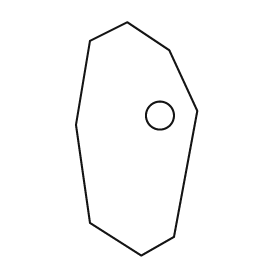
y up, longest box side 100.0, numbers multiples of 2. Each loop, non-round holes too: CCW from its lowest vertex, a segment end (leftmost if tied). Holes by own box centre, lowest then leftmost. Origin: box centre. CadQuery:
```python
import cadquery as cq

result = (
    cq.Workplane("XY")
    .moveTo(2.0, -50.0)
    .lineTo(16.0, -42.0)
    .lineTo(26.0, 12.0)
    .lineTo(14.0, 38.0)
    .lineTo(-4.0, 50.0)
    .lineTo(-20.0, 42.0)
    .lineTo(-26.0, 6.0)
    .lineTo(-20.0, -36.0)
    .close()
    .moveTo(10.0, 10.0)
    .circle(6.0)
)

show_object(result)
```